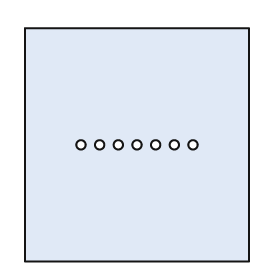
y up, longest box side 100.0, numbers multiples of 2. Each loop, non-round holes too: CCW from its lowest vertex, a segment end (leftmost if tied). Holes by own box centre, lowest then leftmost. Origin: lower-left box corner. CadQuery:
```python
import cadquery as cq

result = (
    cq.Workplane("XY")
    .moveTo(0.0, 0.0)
    .lineTo(96.0, 0.0)
    .lineTo(96.0, 100.0)
    .lineTo(0.0, 100.0)
    .close()
    .moveTo(24.0, 50.0)
    .circle(2.0)
    .moveTo(32.0, 50.0)
    .circle(2.0)
    .moveTo(40.0, 50.0)
    .circle(2.0)
    .moveTo(48.0, 50.0)
    .circle(2.0)
    .moveTo(56.0, 50.0)
    .circle(2.0)
    .moveTo(64.0, 50.0)
    .circle(2.0)
    .moveTo(72.0, 50.0)
    .circle(2.0)
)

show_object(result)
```